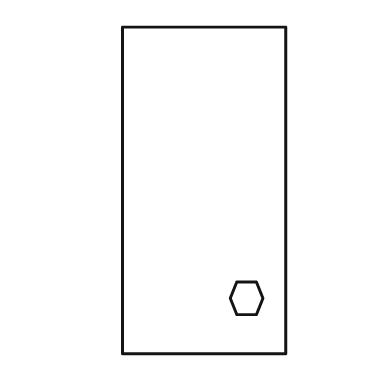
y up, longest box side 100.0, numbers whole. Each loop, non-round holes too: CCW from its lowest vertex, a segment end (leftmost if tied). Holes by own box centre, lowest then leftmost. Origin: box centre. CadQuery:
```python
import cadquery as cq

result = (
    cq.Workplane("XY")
    .moveTo(-25.0, -50.0)
    .lineTo(25.0, -50.0)
    .lineTo(25.0, 50.0)
    .lineTo(-25.0, 50.0)
    .close()
    .moveTo(10.0, -38.0)
    .lineTo(16.0, -38.0)
    .lineTo(18.0, -33.0)
    .lineTo(16.0, -28.0)
    .lineTo(10.0, -28.0)
    .lineTo(8.0, -33.0)
    .close()
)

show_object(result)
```